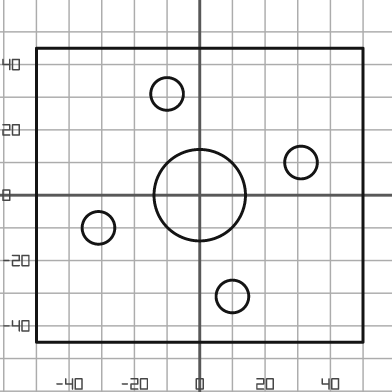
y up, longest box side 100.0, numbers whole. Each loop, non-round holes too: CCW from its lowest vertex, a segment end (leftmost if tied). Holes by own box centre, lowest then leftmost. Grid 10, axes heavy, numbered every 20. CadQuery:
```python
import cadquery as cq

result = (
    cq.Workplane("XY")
    .moveTo(-50.0, -45.0)
    .lineTo(50.0, -45.0)
    .lineTo(50.0, 45.0)
    .lineTo(-50.0, 45.0)
    .close()
    .moveTo(10.0, -31.0)
    .circle(5.0)
    .moveTo(-31.0, -10.0)
    .circle(5.0)
    .moveTo(0.0, 0.0)
    .circle(14.0)
    .moveTo(31.0, 10.0)
    .circle(5.0)
    .moveTo(-10.0, 31.0)
    .circle(5.0)
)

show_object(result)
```